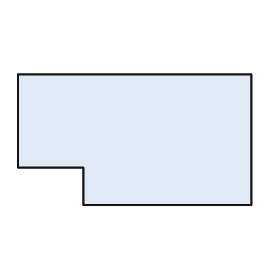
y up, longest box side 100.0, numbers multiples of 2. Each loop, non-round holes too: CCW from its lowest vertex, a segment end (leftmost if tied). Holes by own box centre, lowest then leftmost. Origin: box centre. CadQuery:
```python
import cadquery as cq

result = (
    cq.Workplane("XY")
    .moveTo(-22.0, -28.0)
    .lineTo(50.0, -28.0)
    .lineTo(50.0, 28.0)
    .lineTo(-50.0, 28.0)
    .lineTo(-50.0, -12.0)
    .lineTo(-22.0, -12.0)
    .close()
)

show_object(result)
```